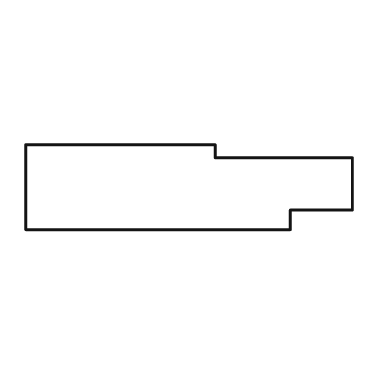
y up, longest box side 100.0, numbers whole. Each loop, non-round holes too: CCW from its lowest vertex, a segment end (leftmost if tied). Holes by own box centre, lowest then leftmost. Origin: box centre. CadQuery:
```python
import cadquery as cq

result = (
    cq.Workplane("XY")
    .moveTo(-50.0, -13.0)
    .lineTo(31.0, -13.0)
    .lineTo(31.0, -7.0)
    .lineTo(50.0, -7.0)
    .lineTo(50.0, 9.0)
    .lineTo(8.0, 9.0)
    .lineTo(8.0, 13.0)
    .lineTo(-50.0, 13.0)
    .close()
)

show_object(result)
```